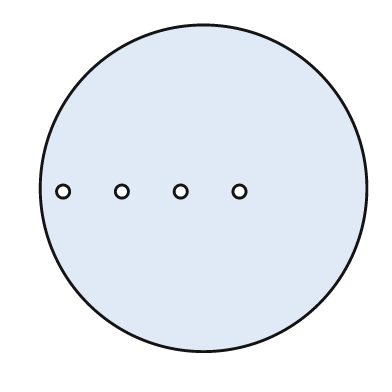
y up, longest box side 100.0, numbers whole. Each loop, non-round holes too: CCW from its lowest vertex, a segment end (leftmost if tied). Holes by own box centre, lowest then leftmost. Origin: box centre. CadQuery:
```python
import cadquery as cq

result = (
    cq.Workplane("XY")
    .moveTo(0.0, 0.0)
    .circle(50.0)
    .moveTo(-43.0, -1.0)
    .circle(2.0)
    .moveTo(-25.0, -1.0)
    .circle(2.0)
    .moveTo(-7.0, -1.0)
    .circle(2.0)
    .moveTo(11.0, -1.0)
    .circle(2.0)
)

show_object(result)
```